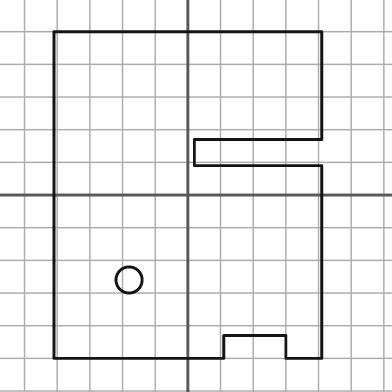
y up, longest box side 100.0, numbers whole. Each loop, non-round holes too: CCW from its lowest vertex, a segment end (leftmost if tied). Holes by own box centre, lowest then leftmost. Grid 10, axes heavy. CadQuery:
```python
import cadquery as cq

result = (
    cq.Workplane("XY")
    .moveTo(-41.0, -50.0)
    .lineTo(11.0, -50.0)
    .lineTo(11.0, -43.0)
    .lineTo(30.0, -43.0)
    .lineTo(30.0, -50.0)
    .lineTo(41.0, -50.0)
    .lineTo(41.0, 9.0)
    .lineTo(2.0, 9.0)
    .lineTo(2.0, 17.0)
    .lineTo(41.0, 17.0)
    .lineTo(41.0, 50.0)
    .lineTo(-41.0, 50.0)
    .close()
    .moveTo(-18.0, -26.0)
    .circle(4.0)
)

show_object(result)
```